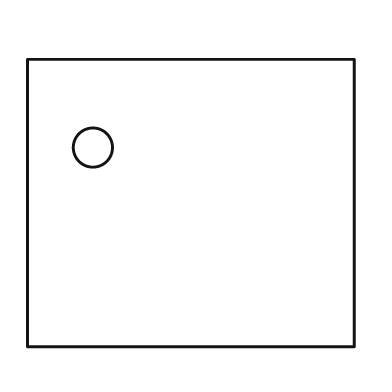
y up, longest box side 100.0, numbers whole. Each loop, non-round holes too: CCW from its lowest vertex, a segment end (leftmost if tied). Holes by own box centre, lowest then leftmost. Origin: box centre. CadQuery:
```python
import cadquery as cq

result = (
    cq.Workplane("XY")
    .moveTo(-50.0, -44.0)
    .lineTo(50.0, -44.0)
    .lineTo(50.0, 44.0)
    .lineTo(-50.0, 44.0)
    .close()
    .moveTo(-30.0, 17.0)
    .circle(6.0)
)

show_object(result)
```